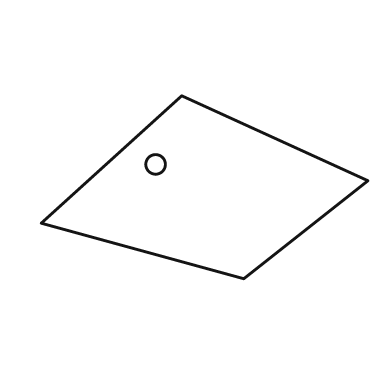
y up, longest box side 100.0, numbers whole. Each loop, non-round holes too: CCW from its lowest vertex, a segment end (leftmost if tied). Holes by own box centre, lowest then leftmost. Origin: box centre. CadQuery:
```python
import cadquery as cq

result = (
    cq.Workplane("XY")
    .moveTo(12.0, -28.0)
    .lineTo(50.0, 2.0)
    .lineTo(-7.0, 28.0)
    .lineTo(-50.0, -11.0)
    .close()
    .moveTo(-15.0, 7.0)
    .circle(3.0)
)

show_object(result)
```